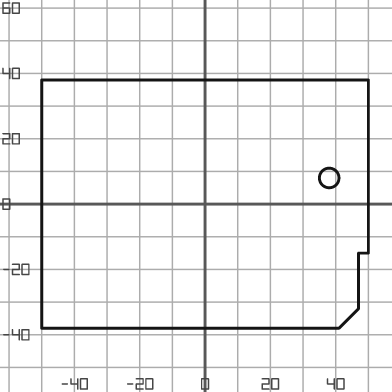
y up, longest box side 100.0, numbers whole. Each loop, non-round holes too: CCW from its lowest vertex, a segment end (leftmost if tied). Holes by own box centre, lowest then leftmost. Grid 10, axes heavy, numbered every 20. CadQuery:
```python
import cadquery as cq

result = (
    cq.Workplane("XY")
    .moveTo(-50.0, -38.0)
    .lineTo(41.0, -38.0)
    .lineTo(47.0, -32.0)
    .lineTo(47.0, -15.0)
    .lineTo(50.0, -15.0)
    .lineTo(50.0, 38.0)
    .lineTo(-50.0, 38.0)
    .close()
    .moveTo(38.0, 8.0)
    .circle(3.0)
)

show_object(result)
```